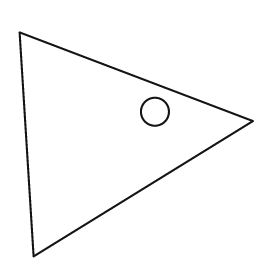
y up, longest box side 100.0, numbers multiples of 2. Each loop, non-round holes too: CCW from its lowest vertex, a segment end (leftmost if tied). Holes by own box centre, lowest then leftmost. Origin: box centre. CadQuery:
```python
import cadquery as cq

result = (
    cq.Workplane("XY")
    .moveTo(-44.0, -48.0)
    .lineTo(50.0, 10.0)
    .lineTo(-50.0, 48.0)
    .close()
    .moveTo(8.0, 14.0)
    .circle(6.0)
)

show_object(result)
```